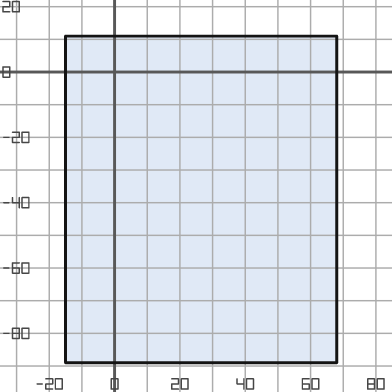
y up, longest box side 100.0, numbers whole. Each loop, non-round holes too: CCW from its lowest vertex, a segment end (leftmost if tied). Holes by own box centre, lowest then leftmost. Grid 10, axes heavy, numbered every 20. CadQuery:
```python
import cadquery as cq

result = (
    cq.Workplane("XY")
    .moveTo(-15.0, -89.0)
    .lineTo(68.0, -89.0)
    .lineTo(68.0, 11.0)
    .lineTo(-15.0, 11.0)
    .close()
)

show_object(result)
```